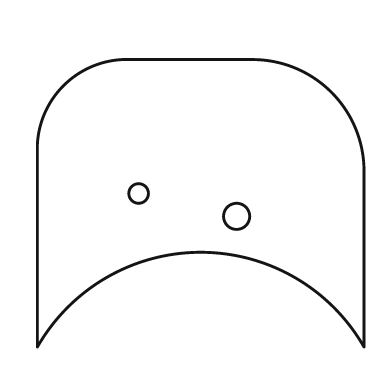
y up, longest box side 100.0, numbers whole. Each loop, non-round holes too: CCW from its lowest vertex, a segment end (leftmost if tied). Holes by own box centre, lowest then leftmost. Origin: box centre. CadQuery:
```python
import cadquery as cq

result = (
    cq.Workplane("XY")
    .moveTo(-50.0, -44.0)
    .threePointArc((0.0, -15.0), (50.0, -44.0))
    .lineTo(50.0, 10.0)
    .threePointArc((40.0, 34.0), (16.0, 44.0))
    .lineTo(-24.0, 44.0)
    .threePointArc((-42.0, 36.0), (-50.0, 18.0))
    .close()
    .moveTo(11.0, -4.0)
    .circle(4.0)
    .moveTo(-19.0, 3.0)
    .circle(3.0)
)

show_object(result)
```